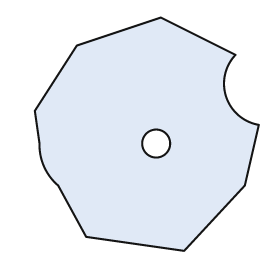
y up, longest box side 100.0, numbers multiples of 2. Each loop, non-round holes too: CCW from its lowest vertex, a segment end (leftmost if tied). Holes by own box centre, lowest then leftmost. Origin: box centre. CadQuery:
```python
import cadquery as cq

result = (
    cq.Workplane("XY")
    .moveTo(16.0, -50.0)
    .lineTo(42.0, -22.0)
    .lineTo(48.0, 4.0)
    .threePointArc((34.0, 16.0), (38.0, 34.0))
    .lineTo(6.0, 50.0)
    .lineTo(-30.0, 38.0)
    .lineTo(-48.0, 10.0)
    .lineTo(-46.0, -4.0)
    .threePointArc((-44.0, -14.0), (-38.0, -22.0))
    .lineTo(-26.0, -44.0)
    .close()
    .moveTo(4.0, -4.0)
    .circle(6.0)
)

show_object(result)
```